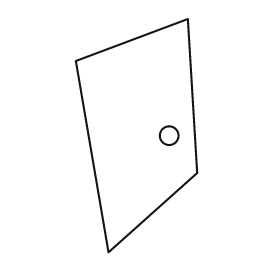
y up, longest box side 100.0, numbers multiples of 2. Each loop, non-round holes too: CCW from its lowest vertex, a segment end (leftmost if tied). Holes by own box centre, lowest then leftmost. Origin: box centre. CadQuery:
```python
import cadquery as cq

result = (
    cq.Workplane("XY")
    .moveTo(-12.0, -50.0)
    .lineTo(26.0, -16.0)
    .lineTo(22.0, 50.0)
    .lineTo(-26.0, 32.0)
    .close()
    .moveTo(14.0, 0.0)
    .circle(4.0)
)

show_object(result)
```